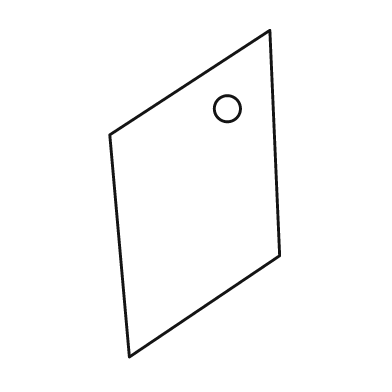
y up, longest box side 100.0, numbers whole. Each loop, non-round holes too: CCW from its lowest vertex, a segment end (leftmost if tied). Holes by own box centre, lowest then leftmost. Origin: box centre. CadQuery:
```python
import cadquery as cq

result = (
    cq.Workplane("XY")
    .moveTo(-20.0, -50.0)
    .lineTo(26.0, -19.0)
    .lineTo(23.0, 50.0)
    .lineTo(-26.0, 18.0)
    .close()
    .moveTo(10.0, 26.0)
    .circle(4.0)
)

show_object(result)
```